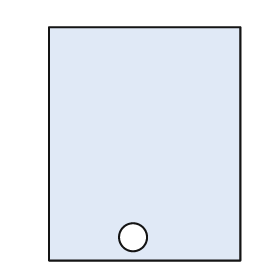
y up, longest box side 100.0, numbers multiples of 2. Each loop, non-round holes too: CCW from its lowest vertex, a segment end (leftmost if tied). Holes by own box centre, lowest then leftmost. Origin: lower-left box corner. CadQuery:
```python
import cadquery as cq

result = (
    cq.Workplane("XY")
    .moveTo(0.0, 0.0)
    .lineTo(82.0, 0.0)
    .lineTo(82.0, 100.0)
    .lineTo(0.0, 100.0)
    .close()
    .moveTo(36.0, 10.0)
    .circle(6.0)
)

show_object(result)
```